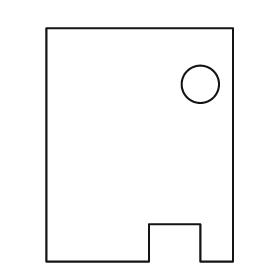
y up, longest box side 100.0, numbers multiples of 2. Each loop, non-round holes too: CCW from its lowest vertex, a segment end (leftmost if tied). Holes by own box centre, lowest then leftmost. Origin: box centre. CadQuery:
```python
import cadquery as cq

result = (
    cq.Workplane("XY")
    .moveTo(-40.0, -50.0)
    .lineTo(4.0, -50.0)
    .lineTo(4.0, -34.0)
    .lineTo(26.0, -34.0)
    .lineTo(26.0, -50.0)
    .lineTo(40.0, -50.0)
    .lineTo(40.0, 50.0)
    .lineTo(-40.0, 50.0)
    .close()
    .moveTo(26.0, 26.0)
    .circle(8.0)
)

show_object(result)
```